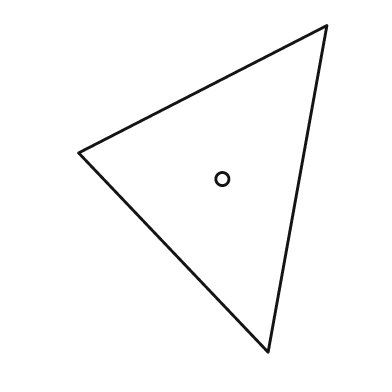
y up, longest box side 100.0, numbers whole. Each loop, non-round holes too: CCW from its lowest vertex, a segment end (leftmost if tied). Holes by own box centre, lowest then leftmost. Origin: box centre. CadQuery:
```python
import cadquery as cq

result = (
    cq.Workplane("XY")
    .moveTo(20.0, -50.0)
    .lineTo(38.0, 50.0)
    .lineTo(-38.0, 11.0)
    .close()
    .moveTo(6.0, 3.0)
    .circle(2.0)
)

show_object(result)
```